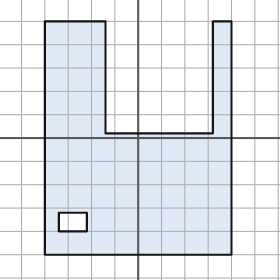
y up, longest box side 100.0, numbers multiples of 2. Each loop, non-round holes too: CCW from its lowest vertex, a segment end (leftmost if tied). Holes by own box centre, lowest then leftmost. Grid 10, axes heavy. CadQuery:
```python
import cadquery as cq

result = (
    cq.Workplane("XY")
    .moveTo(-40.0, -50.0)
    .lineTo(40.0, -50.0)
    .lineTo(40.0, 50.0)
    .lineTo(32.0, 50.0)
    .lineTo(32.0, 2.0)
    .lineTo(-14.0, 2.0)
    .lineTo(-14.0, 50.0)
    .lineTo(-40.0, 50.0)
    .close()
    .moveTo(-34.0, -40.0)
    .lineTo(-22.0, -40.0)
    .lineTo(-22.0, -32.0)
    .lineTo(-34.0, -32.0)
    .close()
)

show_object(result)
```